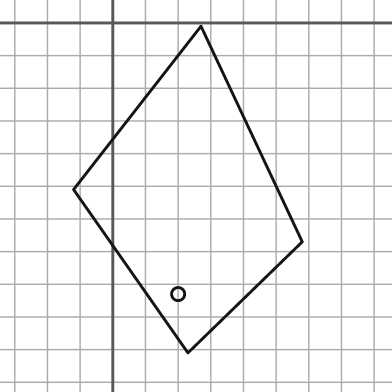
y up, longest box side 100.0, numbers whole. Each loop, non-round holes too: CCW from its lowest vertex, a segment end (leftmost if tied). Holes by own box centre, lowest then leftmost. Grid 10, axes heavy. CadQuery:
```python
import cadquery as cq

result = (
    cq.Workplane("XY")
    .moveTo(23.0, -101.0)
    .lineTo(58.0, -67.0)
    .lineTo(27.0, -1.0)
    .lineTo(-12.0, -51.0)
    .close()
    .moveTo(20.0, -83.0)
    .circle(2.0)
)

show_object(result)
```